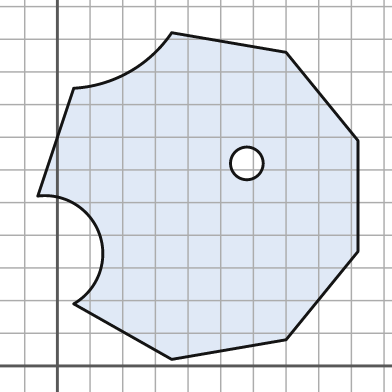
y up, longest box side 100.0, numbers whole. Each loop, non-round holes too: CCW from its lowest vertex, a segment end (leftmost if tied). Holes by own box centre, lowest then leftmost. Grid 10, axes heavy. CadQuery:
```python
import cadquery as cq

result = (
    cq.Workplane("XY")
    .moveTo(35.0, 2.0)
    .lineTo(70.0, 8.0)
    .lineTo(92.0, 35.0)
    .lineTo(92.0, 69.0)
    .lineTo(70.0, 96.0)
    .lineTo(35.0, 102.0)
    .threePointArc((22.0, 90.0), (5.0, 85.0))
    .lineTo(-6.0, 52.0)
    .threePointArc((13.0, 40.0), (5.0, 19.0))
    .close()
    .moveTo(58.0, 62.0)
    .circle(5.0)
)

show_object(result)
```